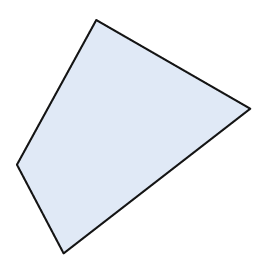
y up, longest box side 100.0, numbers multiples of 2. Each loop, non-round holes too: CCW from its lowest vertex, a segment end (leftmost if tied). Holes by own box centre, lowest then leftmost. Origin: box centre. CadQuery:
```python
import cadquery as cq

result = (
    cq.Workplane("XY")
    .moveTo(-30.0, -50.0)
    .lineTo(50.0, 12.0)
    .lineTo(-16.0, 50.0)
    .lineTo(-50.0, -12.0)
    .close()
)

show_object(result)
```